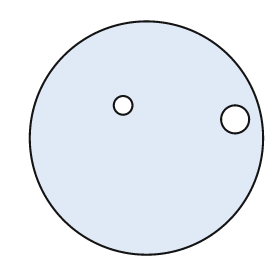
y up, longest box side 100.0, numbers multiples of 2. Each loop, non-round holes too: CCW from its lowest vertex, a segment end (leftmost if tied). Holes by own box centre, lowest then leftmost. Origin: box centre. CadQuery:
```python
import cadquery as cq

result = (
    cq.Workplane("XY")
    .moveTo(0.0, 0.0)
    .circle(50.0)
    .moveTo(38.0, 8.0)
    .circle(6.0)
    .moveTo(-10.0, 14.0)
    .circle(4.0)
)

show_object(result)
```